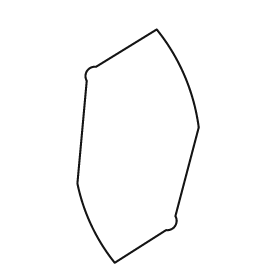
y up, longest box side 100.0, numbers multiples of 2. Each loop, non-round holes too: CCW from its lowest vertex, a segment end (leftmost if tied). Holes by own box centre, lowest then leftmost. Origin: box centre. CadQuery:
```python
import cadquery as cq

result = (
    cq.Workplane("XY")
    .moveTo(-10.0, -50.0)
    .lineTo(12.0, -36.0)
    .threePointArc((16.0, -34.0), (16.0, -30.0))
    .lineTo(26.0, 8.0)
    .threePointArc((20.0, 30.0), (8.0, 50.0))
    .lineTo(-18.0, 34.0)
    .threePointArc((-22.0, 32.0), (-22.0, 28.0))
    .lineTo(-26.0, -16.0)
    .threePointArc((-20.0, -34.0), (-10.0, -50.0))
    .close()
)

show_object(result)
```